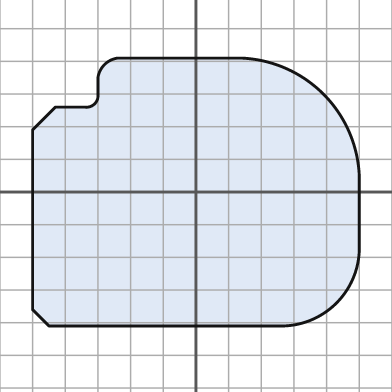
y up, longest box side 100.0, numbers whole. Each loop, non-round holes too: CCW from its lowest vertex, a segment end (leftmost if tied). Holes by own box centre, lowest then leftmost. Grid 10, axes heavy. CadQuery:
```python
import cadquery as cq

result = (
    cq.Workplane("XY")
    .moveTo(-45.0, -41.0)
    .lineTo(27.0, -41.0)
    .threePointArc((43.0, -34.0), (50.0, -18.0))
    .lineTo(50.0, 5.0)
    .threePointArc((39.0, 30.0), (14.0, 41.0))
    .lineTo(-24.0, 41.0)
    .threePointArc((-28.0, 39.0), (-30.0, 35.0))
    .lineTo(-30.0, 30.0)
    .threePointArc((-31.0, 27.0), (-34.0, 26.0))
    .lineTo(-43.0, 26.0)
    .lineTo(-50.0, 19.0)
    .lineTo(-50.0, -36.0)
    .close()
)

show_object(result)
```